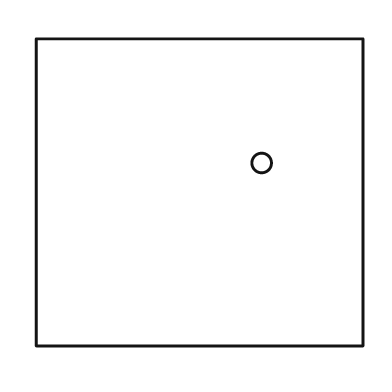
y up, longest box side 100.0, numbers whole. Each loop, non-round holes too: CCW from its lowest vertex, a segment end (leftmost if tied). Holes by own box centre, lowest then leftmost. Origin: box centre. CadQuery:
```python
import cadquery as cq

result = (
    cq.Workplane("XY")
    .moveTo(-50.0, -47.0)
    .lineTo(50.0, -47.0)
    .lineTo(50.0, 47.0)
    .lineTo(-50.0, 47.0)
    .close()
    .moveTo(19.0, 9.0)
    .circle(3.0)
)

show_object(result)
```